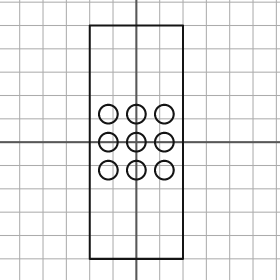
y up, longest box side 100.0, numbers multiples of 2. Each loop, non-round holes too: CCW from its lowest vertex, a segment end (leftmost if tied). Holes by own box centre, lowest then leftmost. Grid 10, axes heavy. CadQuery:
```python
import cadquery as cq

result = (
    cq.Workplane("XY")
    .moveTo(-20.0, -50.0)
    .lineTo(20.0, -50.0)
    .lineTo(20.0, 50.0)
    .lineTo(-20.0, 50.0)
    .close()
    .moveTo(-12.0, -12.0)
    .circle(4.0)
    .moveTo(0.0, -12.0)
    .circle(4.0)
    .moveTo(12.0, -12.0)
    .circle(4.0)
    .moveTo(-12.0, 0.0)
    .circle(4.0)
    .moveTo(0.0, 0.0)
    .circle(4.0)
    .moveTo(12.0, 0.0)
    .circle(4.0)
    .moveTo(-12.0, 12.0)
    .circle(4.0)
    .moveTo(0.0, 12.0)
    .circle(4.0)
    .moveTo(12.0, 12.0)
    .circle(4.0)
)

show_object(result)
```